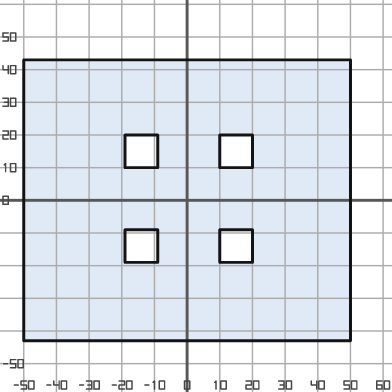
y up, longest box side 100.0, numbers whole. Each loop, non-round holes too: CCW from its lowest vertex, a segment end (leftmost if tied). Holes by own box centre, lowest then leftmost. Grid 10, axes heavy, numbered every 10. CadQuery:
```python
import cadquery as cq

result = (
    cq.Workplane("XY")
    .moveTo(-50.0, -43.0)
    .lineTo(50.0, -43.0)
    .lineTo(50.0, 43.0)
    .lineTo(-50.0, 43.0)
    .close()
    .moveTo(-19.0, -19.0)
    .lineTo(-9.0, -19.0)
    .lineTo(-9.0, -9.0)
    .lineTo(-19.0, -9.0)
    .close()
    .moveTo(10.0, -19.0)
    .lineTo(20.0, -19.0)
    .lineTo(20.0, -9.0)
    .lineTo(10.0, -9.0)
    .close()
    .moveTo(-19.0, 10.0)
    .lineTo(-9.0, 10.0)
    .lineTo(-9.0, 20.0)
    .lineTo(-19.0, 20.0)
    .close()
    .moveTo(10.0, 10.0)
    .lineTo(20.0, 10.0)
    .lineTo(20.0, 20.0)
    .lineTo(10.0, 20.0)
    .close()
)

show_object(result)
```